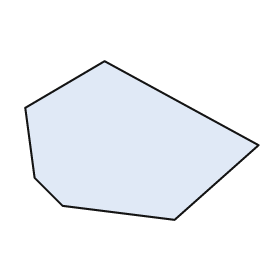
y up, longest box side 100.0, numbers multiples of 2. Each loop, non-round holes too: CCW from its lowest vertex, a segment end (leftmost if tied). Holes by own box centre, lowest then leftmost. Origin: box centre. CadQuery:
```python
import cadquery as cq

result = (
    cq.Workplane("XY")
    .moveTo(14.0, -34.0)
    .lineTo(50.0, -2.0)
    .lineTo(-16.0, 34.0)
    .lineTo(-50.0, 14.0)
    .lineTo(-46.0, -16.0)
    .lineTo(-34.0, -28.0)
    .close()
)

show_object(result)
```